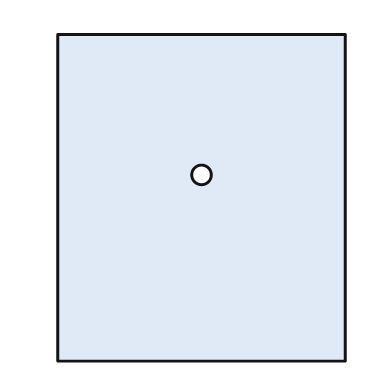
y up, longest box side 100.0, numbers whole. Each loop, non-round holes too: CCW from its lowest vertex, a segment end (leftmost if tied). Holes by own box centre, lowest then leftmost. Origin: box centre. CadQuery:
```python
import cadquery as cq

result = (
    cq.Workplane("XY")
    .moveTo(-44.0, -50.0)
    .lineTo(44.0, -50.0)
    .lineTo(44.0, 50.0)
    .lineTo(-44.0, 50.0)
    .close()
    .moveTo(0.0, 7.0)
    .circle(3.0)
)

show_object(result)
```